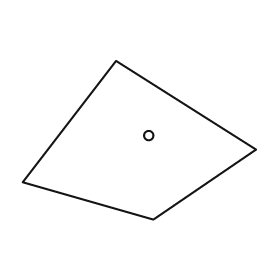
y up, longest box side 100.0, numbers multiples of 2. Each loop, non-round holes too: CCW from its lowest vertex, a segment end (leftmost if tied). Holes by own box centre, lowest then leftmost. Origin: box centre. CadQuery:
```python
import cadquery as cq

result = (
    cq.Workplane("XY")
    .moveTo(6.0, -34.0)
    .lineTo(50.0, -4.0)
    .lineTo(-10.0, 34.0)
    .lineTo(-50.0, -18.0)
    .close()
    .moveTo(4.0, 2.0)
    .circle(2.0)
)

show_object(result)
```